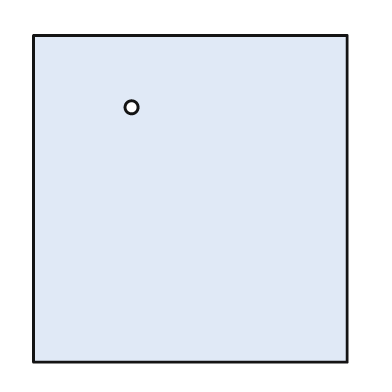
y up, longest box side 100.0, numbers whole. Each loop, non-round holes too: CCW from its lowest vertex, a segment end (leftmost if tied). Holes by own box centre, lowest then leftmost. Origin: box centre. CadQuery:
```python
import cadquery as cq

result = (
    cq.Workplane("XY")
    .moveTo(-48.0, -50.0)
    .lineTo(48.0, -50.0)
    .lineTo(48.0, 50.0)
    .lineTo(-48.0, 50.0)
    .close()
    .moveTo(-18.0, 28.0)
    .circle(2.0)
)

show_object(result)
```